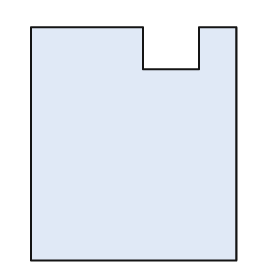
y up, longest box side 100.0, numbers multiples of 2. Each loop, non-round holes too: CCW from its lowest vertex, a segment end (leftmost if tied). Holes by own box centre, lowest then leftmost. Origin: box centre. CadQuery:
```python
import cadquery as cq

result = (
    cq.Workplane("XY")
    .moveTo(-44.0, -50.0)
    .lineTo(44.0, -50.0)
    .lineTo(44.0, 50.0)
    .lineTo(28.0, 50.0)
    .lineTo(28.0, 32.0)
    .lineTo(4.0, 32.0)
    .lineTo(4.0, 50.0)
    .lineTo(-44.0, 50.0)
    .close()
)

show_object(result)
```